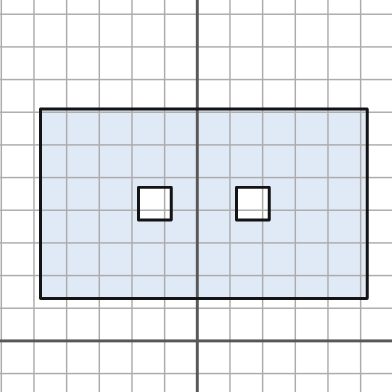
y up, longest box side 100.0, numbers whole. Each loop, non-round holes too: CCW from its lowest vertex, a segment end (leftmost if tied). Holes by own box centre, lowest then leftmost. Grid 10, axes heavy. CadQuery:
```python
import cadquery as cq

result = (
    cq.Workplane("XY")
    .moveTo(-48.0, 13.0)
    .lineTo(52.0, 13.0)
    .lineTo(52.0, 71.0)
    .lineTo(-48.0, 71.0)
    .close()
    .moveTo(-18.0, 37.0)
    .lineTo(-8.0, 37.0)
    .lineTo(-8.0, 47.0)
    .lineTo(-18.0, 47.0)
    .close()
    .moveTo(12.0, 37.0)
    .lineTo(22.0, 37.0)
    .lineTo(22.0, 47.0)
    .lineTo(12.0, 47.0)
    .close()
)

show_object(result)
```